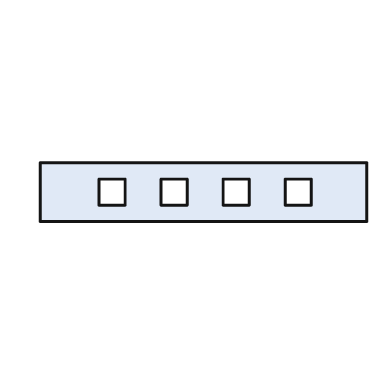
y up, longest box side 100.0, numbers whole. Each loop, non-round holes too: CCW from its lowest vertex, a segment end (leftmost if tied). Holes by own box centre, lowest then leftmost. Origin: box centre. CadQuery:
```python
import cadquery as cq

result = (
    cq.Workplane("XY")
    .moveTo(-50.0, -9.0)
    .lineTo(50.0, -9.0)
    .lineTo(50.0, 9.0)
    .lineTo(-50.0, 9.0)
    .close()
    .moveTo(-32.0, -4.0)
    .lineTo(-24.0, -4.0)
    .lineTo(-24.0, 4.0)
    .lineTo(-32.0, 4.0)
    .close()
    .moveTo(-13.0, -4.0)
    .lineTo(-5.0, -4.0)
    .lineTo(-5.0, 4.0)
    .lineTo(-13.0, 4.0)
    .close()
    .moveTo(6.0, -4.0)
    .lineTo(14.0, -4.0)
    .lineTo(14.0, 4.0)
    .lineTo(6.0, 4.0)
    .close()
    .moveTo(25.0, -4.0)
    .lineTo(33.0, -4.0)
    .lineTo(33.0, 4.0)
    .lineTo(25.0, 4.0)
    .close()
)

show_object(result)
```